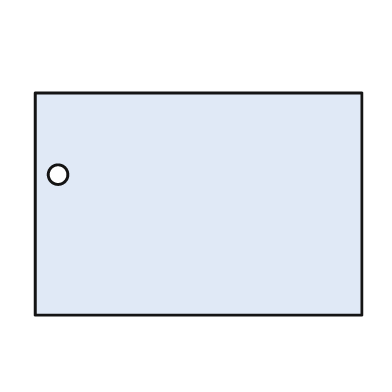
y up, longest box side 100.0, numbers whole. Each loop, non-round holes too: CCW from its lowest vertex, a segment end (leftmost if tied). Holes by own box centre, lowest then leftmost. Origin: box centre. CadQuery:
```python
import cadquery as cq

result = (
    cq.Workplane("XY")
    .moveTo(-50.0, -34.0)
    .lineTo(50.0, -34.0)
    .lineTo(50.0, 34.0)
    .lineTo(-50.0, 34.0)
    .close()
    .moveTo(-43.0, 9.0)
    .circle(3.0)
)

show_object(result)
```